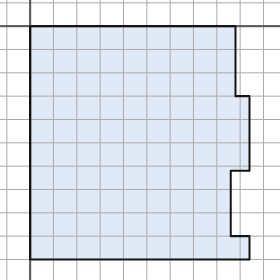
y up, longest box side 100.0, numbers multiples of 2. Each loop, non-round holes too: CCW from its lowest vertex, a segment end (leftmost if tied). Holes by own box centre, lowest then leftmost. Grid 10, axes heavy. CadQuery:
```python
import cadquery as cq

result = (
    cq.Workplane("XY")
    .moveTo(0.0, -100.0)
    .lineTo(94.0, -100.0)
    .lineTo(94.0, -90.0)
    .lineTo(86.0, -90.0)
    .lineTo(86.0, -62.0)
    .lineTo(94.0, -62.0)
    .lineTo(94.0, -30.0)
    .lineTo(88.0, -30.0)
    .lineTo(88.0, 0.0)
    .lineTo(0.0, 0.0)
    .close()
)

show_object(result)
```